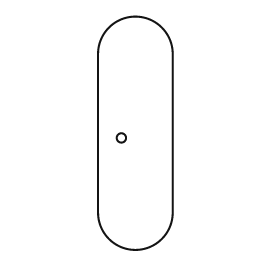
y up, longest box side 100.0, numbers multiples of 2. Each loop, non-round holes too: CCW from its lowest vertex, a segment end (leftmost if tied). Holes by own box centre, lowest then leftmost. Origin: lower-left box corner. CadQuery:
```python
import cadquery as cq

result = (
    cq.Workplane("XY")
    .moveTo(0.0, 16.0)
    .threePointArc((16.0, 0.0), (32.0, 16.0))
    .lineTo(32.0, 84.0)
    .threePointArc((16.0, 100.0), (0.0, 84.0))
    .close()
    .moveTo(10.0, 48.0)
    .circle(2.0)
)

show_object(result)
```